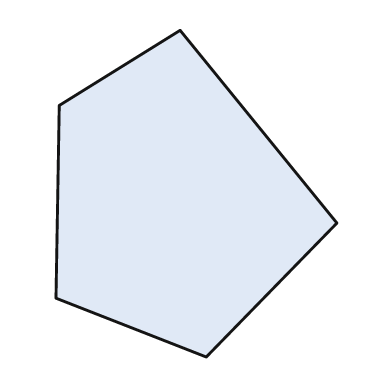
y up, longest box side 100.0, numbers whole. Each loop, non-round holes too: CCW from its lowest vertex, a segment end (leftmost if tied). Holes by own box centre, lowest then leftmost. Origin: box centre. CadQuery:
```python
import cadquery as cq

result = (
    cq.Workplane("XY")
    .moveTo(3.0, -50.0)
    .lineTo(43.0, -9.0)
    .lineTo(-5.0, 50.0)
    .lineTo(-42.0, 27.0)
    .lineTo(-43.0, -32.0)
    .close()
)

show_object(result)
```